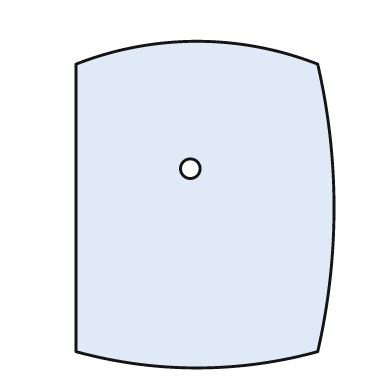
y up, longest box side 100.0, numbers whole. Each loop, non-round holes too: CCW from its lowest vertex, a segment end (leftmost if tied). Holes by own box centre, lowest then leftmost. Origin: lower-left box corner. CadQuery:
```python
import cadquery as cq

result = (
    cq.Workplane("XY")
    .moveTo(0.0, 5.0)
    .threePointArc((37.0, 0.0), (74.0, 5.0))
    .threePointArc((79.0, 49.0), (74.0, 93.0))
    .threePointArc((37.0, 100.0), (0.0, 93.0))
    .close()
    .moveTo(35.0, 61.0)
    .circle(3.0)
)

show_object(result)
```